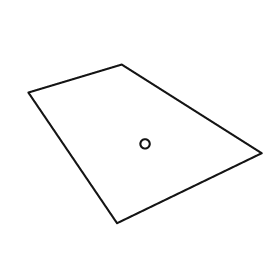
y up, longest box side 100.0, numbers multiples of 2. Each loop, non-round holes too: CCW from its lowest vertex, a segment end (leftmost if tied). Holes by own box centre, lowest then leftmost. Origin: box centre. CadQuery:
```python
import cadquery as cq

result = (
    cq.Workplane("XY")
    .moveTo(-12.0, -34.0)
    .lineTo(50.0, -4.0)
    .lineTo(-10.0, 34.0)
    .lineTo(-50.0, 22.0)
    .close()
    .moveTo(0.0, 0.0)
    .circle(2.0)
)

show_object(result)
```